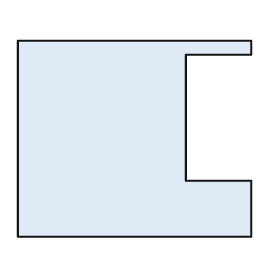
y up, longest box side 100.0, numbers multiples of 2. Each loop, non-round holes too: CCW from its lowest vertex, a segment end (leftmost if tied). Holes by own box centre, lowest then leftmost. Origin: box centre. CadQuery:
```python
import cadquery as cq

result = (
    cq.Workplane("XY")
    .moveTo(-50.0, -42.0)
    .lineTo(50.0, -42.0)
    .lineTo(50.0, -18.0)
    .lineTo(22.0, -18.0)
    .lineTo(22.0, 36.0)
    .lineTo(50.0, 36.0)
    .lineTo(50.0, 42.0)
    .lineTo(-50.0, 42.0)
    .close()
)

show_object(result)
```